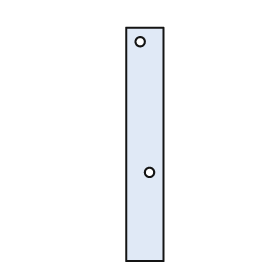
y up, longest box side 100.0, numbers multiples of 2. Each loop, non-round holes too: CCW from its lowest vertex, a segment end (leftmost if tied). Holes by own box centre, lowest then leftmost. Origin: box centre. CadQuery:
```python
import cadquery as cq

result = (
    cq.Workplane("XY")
    .moveTo(-8.0, -50.0)
    .lineTo(8.0, -50.0)
    .lineTo(8.0, 50.0)
    .lineTo(-8.0, 50.0)
    .close()
    .moveTo(2.0, -12.0)
    .circle(2.0)
    .moveTo(-2.0, 44.0)
    .circle(2.0)
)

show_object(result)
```